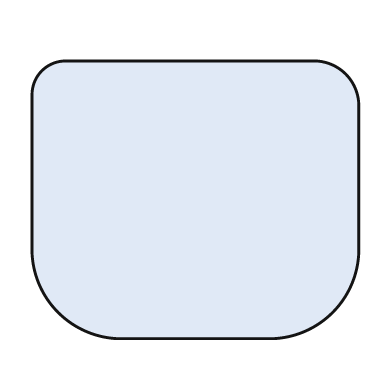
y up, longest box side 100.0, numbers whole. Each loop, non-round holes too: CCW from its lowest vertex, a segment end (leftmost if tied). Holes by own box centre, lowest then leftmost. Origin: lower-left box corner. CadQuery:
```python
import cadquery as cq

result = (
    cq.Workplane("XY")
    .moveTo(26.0, 0.0)
    .lineTo(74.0, 0.0)
    .threePointArc((92.0, 8.0), (100.0, 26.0))
    .lineTo(100.0, 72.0)
    .threePointArc((96.0, 81.0), (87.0, 85.0))
    .lineTo(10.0, 85.0)
    .threePointArc((3.0, 82.0), (0.0, 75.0))
    .lineTo(0.0, 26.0)
    .threePointArc((8.0, 8.0), (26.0, 0.0))
    .close()
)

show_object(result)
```